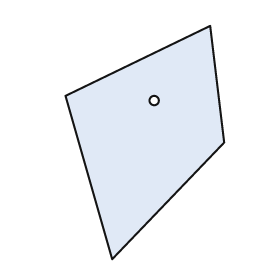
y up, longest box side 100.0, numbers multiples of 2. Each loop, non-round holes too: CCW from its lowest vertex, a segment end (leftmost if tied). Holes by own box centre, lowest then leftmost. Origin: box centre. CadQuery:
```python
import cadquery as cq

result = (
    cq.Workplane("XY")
    .moveTo(-14.0, -50.0)
    .lineTo(34.0, 0.0)
    .lineTo(28.0, 50.0)
    .lineTo(-34.0, 20.0)
    .close()
    .moveTo(4.0, 18.0)
    .circle(2.0)
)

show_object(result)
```